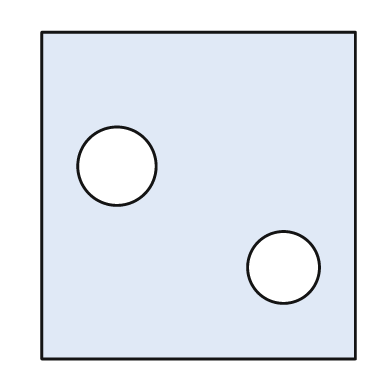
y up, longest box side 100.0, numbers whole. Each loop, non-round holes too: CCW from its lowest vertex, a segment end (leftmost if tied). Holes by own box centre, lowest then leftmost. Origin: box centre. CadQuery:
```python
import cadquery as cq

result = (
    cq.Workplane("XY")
    .moveTo(-48.0, -50.0)
    .lineTo(48.0, -50.0)
    .lineTo(48.0, 50.0)
    .lineTo(-48.0, 50.0)
    .close()
    .moveTo(26.0, -22.0)
    .circle(11.0)
    .moveTo(-25.0, 9.0)
    .circle(12.0)
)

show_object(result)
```